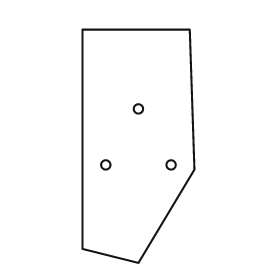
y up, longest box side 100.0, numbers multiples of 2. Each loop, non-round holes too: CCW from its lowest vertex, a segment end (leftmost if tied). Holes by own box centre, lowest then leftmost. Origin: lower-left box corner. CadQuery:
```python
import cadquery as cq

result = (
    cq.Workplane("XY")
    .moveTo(24.0, 0.0)
    .lineTo(48.0, 40.0)
    .lineTo(46.0, 100.0)
    .lineTo(0.0, 100.0)
    .lineTo(0.0, 6.0)
    .close()
    .moveTo(10.0, 42.0)
    .circle(2.0)
    .moveTo(38.0, 42.0)
    .circle(2.0)
    .moveTo(24.0, 66.0)
    .circle(2.0)
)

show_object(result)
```